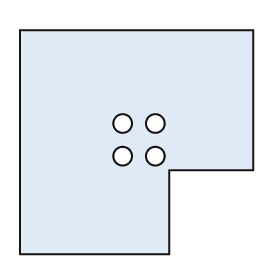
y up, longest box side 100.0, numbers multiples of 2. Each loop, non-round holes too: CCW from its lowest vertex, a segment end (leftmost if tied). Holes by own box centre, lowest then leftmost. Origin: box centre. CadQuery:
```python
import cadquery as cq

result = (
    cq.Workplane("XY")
    .moveTo(-50.0, -48.0)
    .lineTo(14.0, -48.0)
    .lineTo(14.0, -12.0)
    .lineTo(50.0, -12.0)
    .lineTo(50.0, 48.0)
    .lineTo(-50.0, 48.0)
    .close()
    .moveTo(-6.0, -6.0)
    .circle(4.0)
    .moveTo(8.0, -6.0)
    .circle(4.0)
    .moveTo(-6.0, 8.0)
    .circle(4.0)
    .moveTo(8.0, 8.0)
    .circle(4.0)
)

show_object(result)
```